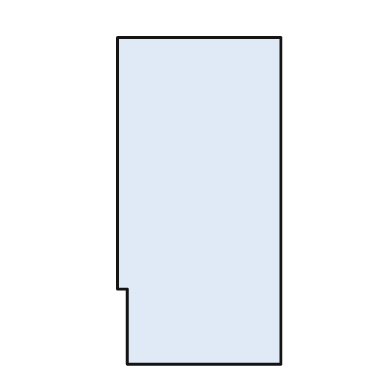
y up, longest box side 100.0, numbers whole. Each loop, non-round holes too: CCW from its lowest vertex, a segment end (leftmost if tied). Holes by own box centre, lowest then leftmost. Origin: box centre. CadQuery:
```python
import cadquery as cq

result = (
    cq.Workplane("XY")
    .moveTo(-22.0, -50.0)
    .lineTo(25.0, -50.0)
    .lineTo(25.0, 50.0)
    .lineTo(-25.0, 50.0)
    .lineTo(-25.0, -27.0)
    .lineTo(-22.0, -27.0)
    .close()
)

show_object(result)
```